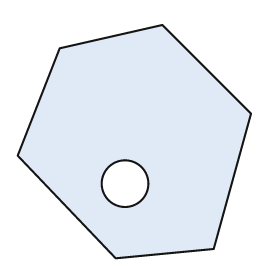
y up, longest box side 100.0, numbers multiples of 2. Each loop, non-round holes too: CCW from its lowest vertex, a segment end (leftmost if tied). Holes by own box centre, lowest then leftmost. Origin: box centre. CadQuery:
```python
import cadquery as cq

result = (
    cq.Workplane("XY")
    .moveTo(-8.0, -50.0)
    .lineTo(34.0, -46.0)
    .lineTo(50.0, 12.0)
    .lineTo(12.0, 50.0)
    .lineTo(-32.0, 40.0)
    .lineTo(-50.0, -6.0)
    .close()
    .moveTo(-4.0, -18.0)
    .circle(10.0)
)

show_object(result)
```